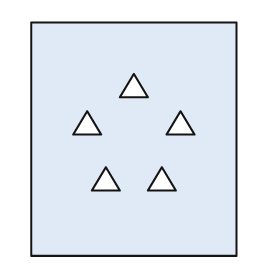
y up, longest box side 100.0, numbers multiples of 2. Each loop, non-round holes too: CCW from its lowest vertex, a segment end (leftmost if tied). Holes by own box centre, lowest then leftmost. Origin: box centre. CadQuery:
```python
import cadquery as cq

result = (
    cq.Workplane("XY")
    .moveTo(-44.0, -50.0)
    .lineTo(44.0, -50.0)
    .lineTo(44.0, 50.0)
    .lineTo(-44.0, 50.0)
    .close()
    .moveTo(-18.0, -22.0)
    .lineTo(-6.0, -22.0)
    .lineTo(-12.0, -12.0)
    .close()
    .moveTo(6.0, -22.0)
    .lineTo(18.0, -22.0)
    .lineTo(12.0, -12.0)
    .close()
    .moveTo(-26.0, 2.0)
    .lineTo(-14.0, 2.0)
    .lineTo(-20.0, 12.0)
    .close()
    .moveTo(14.0, 2.0)
    .lineTo(26.0, 2.0)
    .lineTo(20.0, 12.0)
    .close()
    .moveTo(-6.0, 18.0)
    .lineTo(6.0, 18.0)
    .lineTo(0.0, 28.0)
    .close()
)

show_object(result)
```